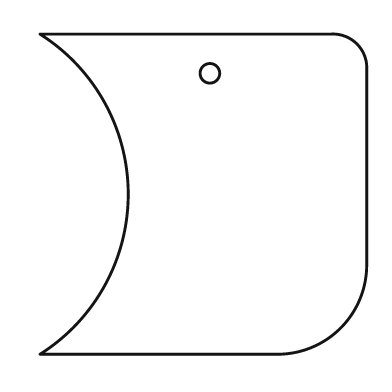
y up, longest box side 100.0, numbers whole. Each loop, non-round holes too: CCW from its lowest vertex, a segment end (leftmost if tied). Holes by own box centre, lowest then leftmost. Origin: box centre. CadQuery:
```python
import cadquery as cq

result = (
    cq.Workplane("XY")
    .moveTo(-50.0, -49.0)
    .lineTo(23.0, -49.0)
    .threePointArc((42.0, -41.0), (50.0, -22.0))
    .lineTo(50.0, 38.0)
    .threePointArc((47.0, 46.0), (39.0, 49.0))
    .lineTo(-50.0, 49.0)
    .threePointArc((-23.0, 0.0), (-50.0, -49.0))
    .close()
    .moveTo(2.0, 37.0)
    .circle(3.0)
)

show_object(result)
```